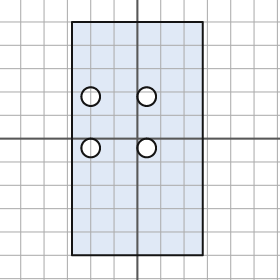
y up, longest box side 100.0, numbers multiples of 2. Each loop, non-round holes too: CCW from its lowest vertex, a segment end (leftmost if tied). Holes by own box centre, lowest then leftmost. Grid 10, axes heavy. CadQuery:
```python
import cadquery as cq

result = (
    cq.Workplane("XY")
    .moveTo(-28.0, -50.0)
    .lineTo(28.0, -50.0)
    .lineTo(28.0, 50.0)
    .lineTo(-28.0, 50.0)
    .close()
    .moveTo(-20.0, -4.0)
    .circle(4.0)
    .moveTo(4.0, -4.0)
    .circle(4.0)
    .moveTo(-20.0, 18.0)
    .circle(4.0)
    .moveTo(4.0, 18.0)
    .circle(4.0)
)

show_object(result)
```